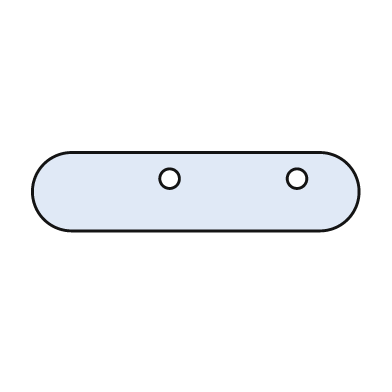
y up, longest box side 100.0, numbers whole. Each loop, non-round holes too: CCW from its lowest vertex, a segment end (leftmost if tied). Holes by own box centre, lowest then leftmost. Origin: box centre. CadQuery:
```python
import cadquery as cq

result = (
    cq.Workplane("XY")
    .moveTo(-38.0, -12.0)
    .lineTo(38.0, -12.0)
    .threePointArc((50.0, 0.0), (38.0, 12.0))
    .lineTo(-38.0, 12.0)
    .threePointArc((-50.0, 0.0), (-38.0, -12.0))
    .close()
    .moveTo(-8.0, 4.0)
    .circle(3.0)
    .moveTo(31.0, 4.0)
    .circle(3.0)
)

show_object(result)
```